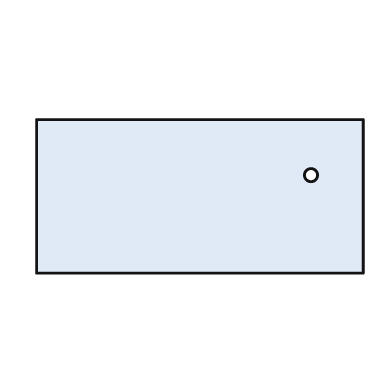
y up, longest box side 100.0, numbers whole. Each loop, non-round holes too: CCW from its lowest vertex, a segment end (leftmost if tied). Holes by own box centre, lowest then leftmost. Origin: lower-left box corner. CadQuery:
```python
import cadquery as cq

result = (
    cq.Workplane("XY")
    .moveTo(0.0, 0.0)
    .lineTo(100.0, 0.0)
    .lineTo(100.0, 47.0)
    .lineTo(0.0, 47.0)
    .close()
    .moveTo(84.0, 30.0)
    .circle(2.0)
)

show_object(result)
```